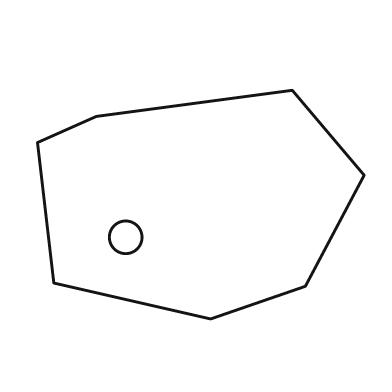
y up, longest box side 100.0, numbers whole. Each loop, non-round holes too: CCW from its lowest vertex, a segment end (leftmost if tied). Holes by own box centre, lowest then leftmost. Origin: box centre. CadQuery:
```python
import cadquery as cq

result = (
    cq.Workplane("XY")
    .moveTo(3.0, -35.0)
    .lineTo(32.0, -25.0)
    .lineTo(50.0, 9.0)
    .lineTo(28.0, 35.0)
    .lineTo(-32.0, 27.0)
    .lineTo(-50.0, 19.0)
    .lineTo(-45.0, -24.0)
    .close()
    .moveTo(-23.0, -10.0)
    .circle(5.0)
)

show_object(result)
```